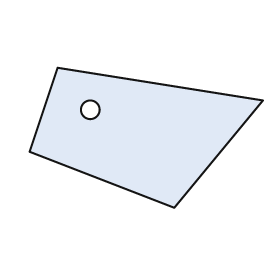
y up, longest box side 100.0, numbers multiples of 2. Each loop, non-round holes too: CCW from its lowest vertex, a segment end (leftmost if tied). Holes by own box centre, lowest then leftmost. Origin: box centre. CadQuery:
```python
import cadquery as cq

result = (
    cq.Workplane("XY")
    .moveTo(12.0, -30.0)
    .lineTo(50.0, 16.0)
    .lineTo(-38.0, 30.0)
    .lineTo(-50.0, -6.0)
    .close()
    .moveTo(-24.0, 12.0)
    .circle(4.0)
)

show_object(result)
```